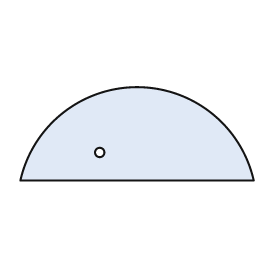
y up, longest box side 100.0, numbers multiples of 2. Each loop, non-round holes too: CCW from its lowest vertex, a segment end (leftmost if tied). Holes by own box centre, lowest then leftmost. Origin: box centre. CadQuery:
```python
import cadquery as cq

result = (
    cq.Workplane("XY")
    .moveTo(-50.0, -20.0)
    .lineTo(50.0, -20.0)
    .threePointArc((0.0, 20.0), (-50.0, -20.0))
    .close()
    .moveTo(-16.0, -8.0)
    .circle(2.0)
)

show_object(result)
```